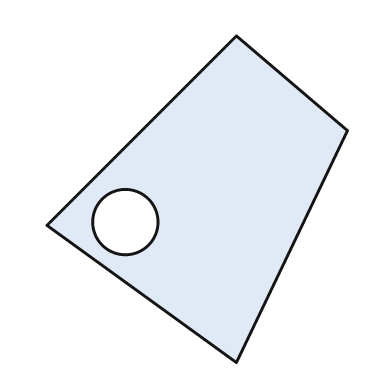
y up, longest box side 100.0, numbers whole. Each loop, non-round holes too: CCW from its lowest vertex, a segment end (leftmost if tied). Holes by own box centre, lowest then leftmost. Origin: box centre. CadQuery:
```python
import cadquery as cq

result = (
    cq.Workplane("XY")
    .moveTo(12.0, -50.0)
    .lineTo(46.0, 21.0)
    .lineTo(12.0, 50.0)
    .lineTo(-46.0, -8.0)
    .close()
    .moveTo(-22.0, -7.0)
    .circle(10.0)
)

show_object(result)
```